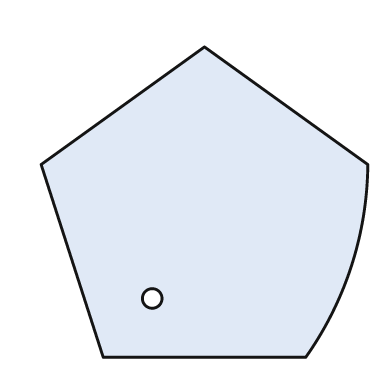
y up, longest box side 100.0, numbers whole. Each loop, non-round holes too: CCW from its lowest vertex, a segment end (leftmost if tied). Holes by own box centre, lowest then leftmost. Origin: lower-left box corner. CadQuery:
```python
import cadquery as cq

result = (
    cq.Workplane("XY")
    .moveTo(19.0, 0.0)
    .lineTo(81.0, 0.0)
    .threePointArc((95.0, 28.0), (100.0, 59.0))
    .lineTo(50.0, 95.0)
    .lineTo(0.0, 59.0)
    .close()
    .moveTo(34.0, 18.0)
    .circle(3.0)
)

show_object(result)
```